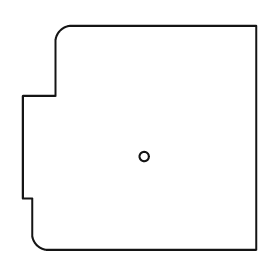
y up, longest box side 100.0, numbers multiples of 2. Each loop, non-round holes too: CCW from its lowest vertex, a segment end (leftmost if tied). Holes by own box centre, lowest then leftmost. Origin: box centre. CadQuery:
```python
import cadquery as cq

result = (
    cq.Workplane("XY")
    .moveTo(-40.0, -48.0)
    .lineTo(50.0, -48.0)
    .lineTo(50.0, 48.0)
    .lineTo(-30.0, 48.0)
    .threePointArc((-34.0, 46.0), (-36.0, 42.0))
    .lineTo(-36.0, 18.0)
    .lineTo(-50.0, 18.0)
    .lineTo(-50.0, -26.0)
    .lineTo(-46.0, -26.0)
    .lineTo(-46.0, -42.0)
    .threePointArc((-44.0, -46.0), (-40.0, -48.0))
    .close()
    .moveTo(2.0, -8.0)
    .circle(2.0)
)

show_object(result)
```